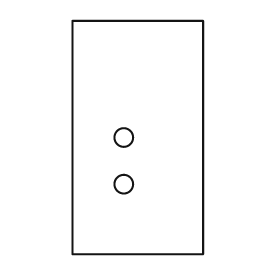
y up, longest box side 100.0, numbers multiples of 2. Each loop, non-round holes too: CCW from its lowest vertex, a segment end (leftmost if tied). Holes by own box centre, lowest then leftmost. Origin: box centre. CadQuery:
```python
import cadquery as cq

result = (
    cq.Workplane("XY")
    .moveTo(-28.0, -50.0)
    .lineTo(28.0, -50.0)
    .lineTo(28.0, 50.0)
    .lineTo(-28.0, 50.0)
    .close()
    .moveTo(-6.0, -20.0)
    .circle(4.0)
    .moveTo(-6.0, 0.0)
    .circle(4.0)
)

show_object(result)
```